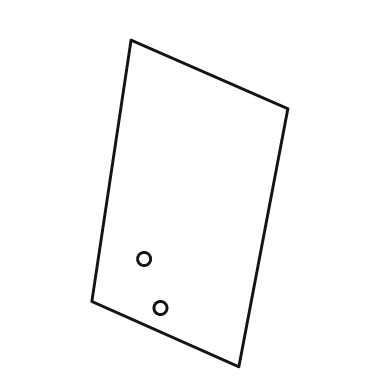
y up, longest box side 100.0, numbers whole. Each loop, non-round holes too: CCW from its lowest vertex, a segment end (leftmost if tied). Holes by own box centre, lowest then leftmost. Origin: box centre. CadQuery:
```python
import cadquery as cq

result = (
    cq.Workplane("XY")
    .moveTo(15.0, -50.0)
    .lineTo(30.0, 29.0)
    .lineTo(-18.0, 50.0)
    .lineTo(-30.0, -30.0)
    .close()
    .moveTo(-9.0, -32.0)
    .circle(2.0)
    .moveTo(-14.0, -17.0)
    .circle(2.0)
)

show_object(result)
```